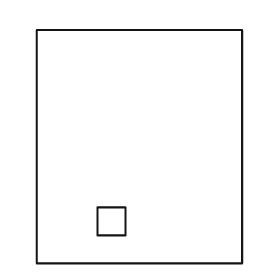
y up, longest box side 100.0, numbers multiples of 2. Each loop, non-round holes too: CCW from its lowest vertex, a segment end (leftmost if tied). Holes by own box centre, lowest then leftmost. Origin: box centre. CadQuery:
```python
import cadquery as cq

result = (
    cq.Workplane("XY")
    .moveTo(-44.0, -50.0)
    .lineTo(44.0, -50.0)
    .lineTo(44.0, 50.0)
    .lineTo(-44.0, 50.0)
    .close()
    .moveTo(-18.0, -38.0)
    .lineTo(-6.0, -38.0)
    .lineTo(-6.0, -26.0)
    .lineTo(-18.0, -26.0)
    .close()
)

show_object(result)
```